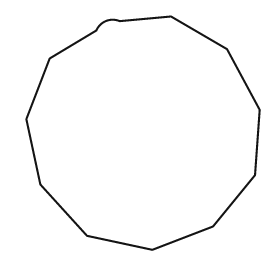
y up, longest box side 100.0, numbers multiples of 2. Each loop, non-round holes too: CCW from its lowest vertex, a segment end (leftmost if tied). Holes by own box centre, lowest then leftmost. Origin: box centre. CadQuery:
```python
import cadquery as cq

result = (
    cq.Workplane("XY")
    .moveTo(4.0, -50.0)
    .lineTo(30.0, -40.0)
    .lineTo(48.0, -18.0)
    .lineTo(50.0, 10.0)
    .lineTo(36.0, 36.0)
    .lineTo(12.0, 50.0)
    .lineTo(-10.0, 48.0)
    .threePointArc((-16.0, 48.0), (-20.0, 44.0))
    .lineTo(-40.0, 32.0)
    .lineTo(-50.0, 6.0)
    .lineTo(-44.0, -22.0)
    .lineTo(-24.0, -44.0)
    .close()
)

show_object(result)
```